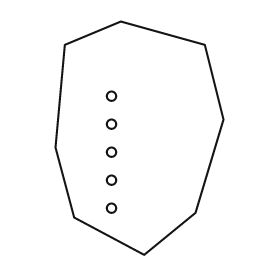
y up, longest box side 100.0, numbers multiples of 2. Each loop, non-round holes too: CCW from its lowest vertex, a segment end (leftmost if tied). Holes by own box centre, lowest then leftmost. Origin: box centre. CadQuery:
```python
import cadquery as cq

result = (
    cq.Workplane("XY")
    .moveTo(2.0, -50.0)
    .lineTo(24.0, -32.0)
    .lineTo(36.0, 8.0)
    .lineTo(28.0, 40.0)
    .lineTo(-8.0, 50.0)
    .lineTo(-32.0, 40.0)
    .lineTo(-36.0, -4.0)
    .lineTo(-28.0, -34.0)
    .close()
    .moveTo(-12.0, -30.0)
    .circle(2.0)
    .moveTo(-12.0, -18.0)
    .circle(2.0)
    .moveTo(-12.0, -6.0)
    .circle(2.0)
    .moveTo(-12.0, 6.0)
    .circle(2.0)
    .moveTo(-12.0, 18.0)
    .circle(2.0)
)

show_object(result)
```